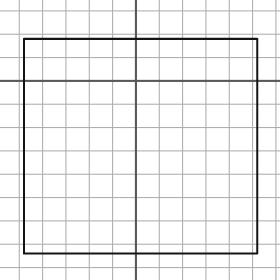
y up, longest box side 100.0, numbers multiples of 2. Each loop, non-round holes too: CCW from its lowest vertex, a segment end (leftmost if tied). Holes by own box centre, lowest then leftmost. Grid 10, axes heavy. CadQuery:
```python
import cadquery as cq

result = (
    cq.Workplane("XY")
    .moveTo(-48.0, -74.0)
    .lineTo(52.0, -74.0)
    .lineTo(52.0, 18.0)
    .lineTo(-48.0, 18.0)
    .close()
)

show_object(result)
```